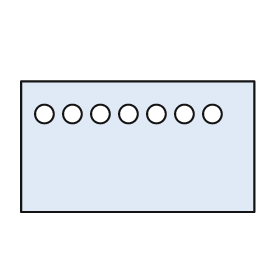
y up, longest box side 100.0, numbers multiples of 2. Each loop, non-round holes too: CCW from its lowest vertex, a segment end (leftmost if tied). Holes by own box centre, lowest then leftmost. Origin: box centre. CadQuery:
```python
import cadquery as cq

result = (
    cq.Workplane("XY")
    .moveTo(-50.0, -28.0)
    .lineTo(50.0, -28.0)
    .lineTo(50.0, 28.0)
    .lineTo(-50.0, 28.0)
    .close()
    .moveTo(-40.0, 14.0)
    .circle(4.0)
    .moveTo(-28.0, 14.0)
    .circle(4.0)
    .moveTo(-16.0, 14.0)
    .circle(4.0)
    .moveTo(-4.0, 14.0)
    .circle(4.0)
    .moveTo(8.0, 14.0)
    .circle(4.0)
    .moveTo(20.0, 14.0)
    .circle(4.0)
    .moveTo(32.0, 14.0)
    .circle(4.0)
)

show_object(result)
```